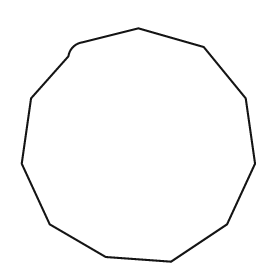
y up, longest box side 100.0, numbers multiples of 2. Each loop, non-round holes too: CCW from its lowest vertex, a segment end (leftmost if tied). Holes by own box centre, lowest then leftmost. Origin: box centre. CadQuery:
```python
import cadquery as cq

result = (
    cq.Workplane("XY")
    .moveTo(14.0, -50.0)
    .lineTo(38.0, -34.0)
    .lineTo(50.0, -8.0)
    .lineTo(46.0, 20.0)
    .lineTo(28.0, 42.0)
    .lineTo(0.0, 50.0)
    .lineTo(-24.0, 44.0)
    .threePointArc((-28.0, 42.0), (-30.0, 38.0))
    .lineTo(-46.0, 20.0)
    .lineTo(-50.0, -8.0)
    .lineTo(-38.0, -34.0)
    .lineTo(-14.0, -48.0)
    .close()
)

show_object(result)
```